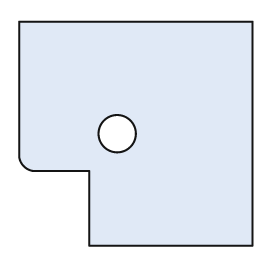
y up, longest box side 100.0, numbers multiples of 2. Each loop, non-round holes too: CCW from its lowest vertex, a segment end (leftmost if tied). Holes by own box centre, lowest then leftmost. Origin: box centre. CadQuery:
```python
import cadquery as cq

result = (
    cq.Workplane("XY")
    .moveTo(-20.0, -48.0)
    .lineTo(50.0, -48.0)
    .lineTo(50.0, 48.0)
    .lineTo(-50.0, 48.0)
    .lineTo(-50.0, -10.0)
    .threePointArc((-48.0, -14.0), (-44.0, -16.0))
    .lineTo(-20.0, -16.0)
    .close()
    .moveTo(-8.0, 0.0)
    .circle(8.0)
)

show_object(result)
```